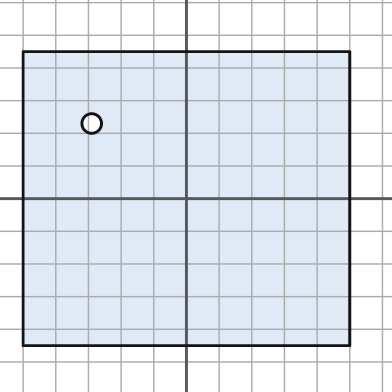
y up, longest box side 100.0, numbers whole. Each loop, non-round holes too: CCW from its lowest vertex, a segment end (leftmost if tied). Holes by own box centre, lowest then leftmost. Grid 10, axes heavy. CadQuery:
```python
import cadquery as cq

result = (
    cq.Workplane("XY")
    .moveTo(-50.0, -45.0)
    .lineTo(50.0, -45.0)
    .lineTo(50.0, 45.0)
    .lineTo(-50.0, 45.0)
    .close()
    .moveTo(-29.0, 23.0)
    .circle(3.0)
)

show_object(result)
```